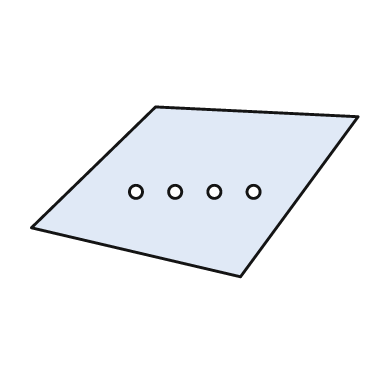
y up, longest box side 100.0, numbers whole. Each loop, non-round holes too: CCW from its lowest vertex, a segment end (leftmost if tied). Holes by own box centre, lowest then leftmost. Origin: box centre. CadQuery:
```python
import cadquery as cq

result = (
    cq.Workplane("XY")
    .moveTo(14.0, -26.0)
    .lineTo(50.0, 23.0)
    .lineTo(-12.0, 26.0)
    .lineTo(-50.0, -11.0)
    .close()
    .moveTo(-18.0, 0.0)
    .circle(2.0)
    .moveTo(-6.0, 0.0)
    .circle(2.0)
    .moveTo(6.0, 0.0)
    .circle(2.0)
    .moveTo(18.0, 0.0)
    .circle(2.0)
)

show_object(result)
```